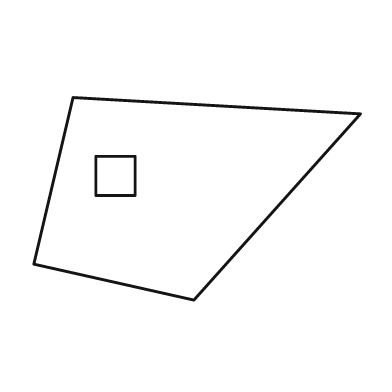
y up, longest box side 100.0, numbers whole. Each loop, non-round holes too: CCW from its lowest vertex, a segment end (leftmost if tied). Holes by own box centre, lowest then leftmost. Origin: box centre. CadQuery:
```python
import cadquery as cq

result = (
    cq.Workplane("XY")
    .moveTo(-1.0, -31.0)
    .lineTo(50.0, 26.0)
    .lineTo(-38.0, 31.0)
    .lineTo(-50.0, -20.0)
    .close()
    .moveTo(-31.0, 1.0)
    .lineTo(-19.0, 1.0)
    .lineTo(-19.0, 13.0)
    .lineTo(-31.0, 13.0)
    .close()
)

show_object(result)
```